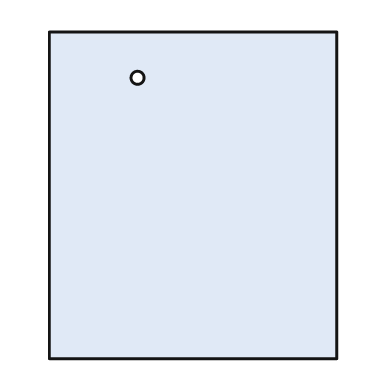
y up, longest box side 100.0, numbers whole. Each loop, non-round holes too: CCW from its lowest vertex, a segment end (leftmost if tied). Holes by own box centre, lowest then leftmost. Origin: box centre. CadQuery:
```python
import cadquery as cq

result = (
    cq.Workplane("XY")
    .moveTo(-44.0, -50.0)
    .lineTo(44.0, -50.0)
    .lineTo(44.0, 50.0)
    .lineTo(-44.0, 50.0)
    .close()
    .moveTo(-17.0, 36.0)
    .circle(2.0)
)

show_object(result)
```